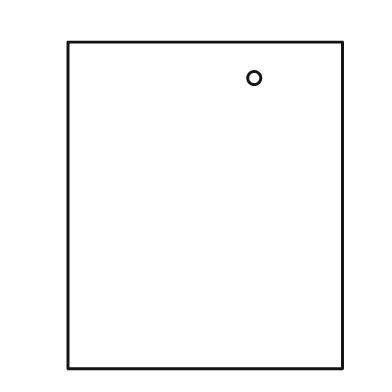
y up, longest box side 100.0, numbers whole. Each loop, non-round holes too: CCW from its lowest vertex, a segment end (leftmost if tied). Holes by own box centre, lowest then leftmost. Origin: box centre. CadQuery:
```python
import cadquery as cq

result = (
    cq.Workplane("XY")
    .moveTo(-42.0, -50.0)
    .lineTo(42.0, -50.0)
    .lineTo(42.0, 50.0)
    .lineTo(-42.0, 50.0)
    .close()
    .moveTo(15.0, 39.0)
    .circle(2.0)
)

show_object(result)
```